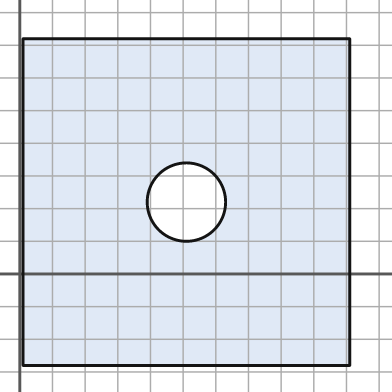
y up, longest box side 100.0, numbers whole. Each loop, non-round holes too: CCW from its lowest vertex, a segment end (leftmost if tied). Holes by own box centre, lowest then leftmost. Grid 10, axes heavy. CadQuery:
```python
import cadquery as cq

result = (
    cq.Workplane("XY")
    .moveTo(1.0, -28.0)
    .lineTo(101.0, -28.0)
    .lineTo(101.0, 72.0)
    .lineTo(1.0, 72.0)
    .close()
    .moveTo(51.0, 22.0)
    .circle(12.0)
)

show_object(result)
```